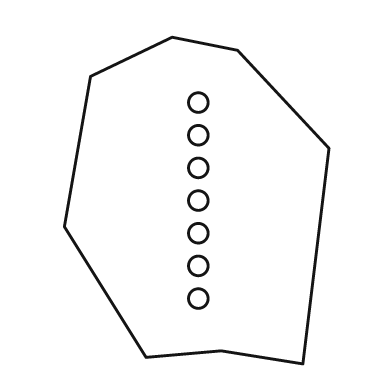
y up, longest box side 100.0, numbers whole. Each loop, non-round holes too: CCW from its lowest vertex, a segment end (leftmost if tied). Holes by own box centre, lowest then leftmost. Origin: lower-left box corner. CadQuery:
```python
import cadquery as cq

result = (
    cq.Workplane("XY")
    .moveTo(73.0, 0.0)
    .lineTo(81.0, 66.0)
    .lineTo(53.0, 96.0)
    .lineTo(33.0, 100.0)
    .lineTo(8.0, 88.0)
    .lineTo(0.0, 42.0)
    .lineTo(25.0, 2.0)
    .lineTo(48.0, 4.0)
    .close()
    .moveTo(41.0, 20.0)
    .circle(3.0)
    .moveTo(41.0, 30.0)
    .circle(3.0)
    .moveTo(41.0, 40.0)
    .circle(3.0)
    .moveTo(41.0, 50.0)
    .circle(3.0)
    .moveTo(41.0, 60.0)
    .circle(3.0)
    .moveTo(41.0, 70.0)
    .circle(3.0)
    .moveTo(41.0, 80.0)
    .circle(3.0)
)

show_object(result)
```